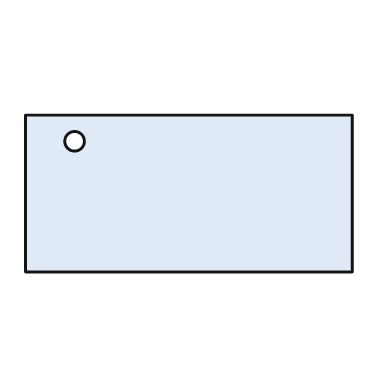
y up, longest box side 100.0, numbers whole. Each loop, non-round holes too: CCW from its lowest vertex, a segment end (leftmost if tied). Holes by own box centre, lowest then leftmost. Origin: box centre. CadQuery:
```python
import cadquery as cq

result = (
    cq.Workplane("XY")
    .moveTo(-50.0, -24.0)
    .lineTo(50.0, -24.0)
    .lineTo(50.0, 24.0)
    .lineTo(-50.0, 24.0)
    .close()
    .moveTo(-35.0, 16.0)
    .circle(3.0)
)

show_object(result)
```